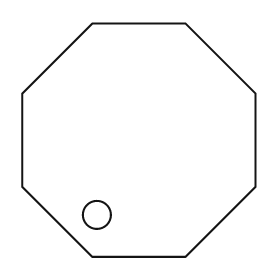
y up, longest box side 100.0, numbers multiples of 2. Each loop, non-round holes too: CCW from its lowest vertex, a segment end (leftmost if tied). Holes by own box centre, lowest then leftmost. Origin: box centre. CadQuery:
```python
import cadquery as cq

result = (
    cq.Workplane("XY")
    .moveTo(-20.0, -50.0)
    .lineTo(20.0, -50.0)
    .lineTo(50.0, -20.0)
    .lineTo(50.0, 20.0)
    .lineTo(20.0, 50.0)
    .lineTo(-20.0, 50.0)
    .lineTo(-50.0, 20.0)
    .lineTo(-50.0, -20.0)
    .close()
    .moveTo(-18.0, -32.0)
    .circle(6.0)
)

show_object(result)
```